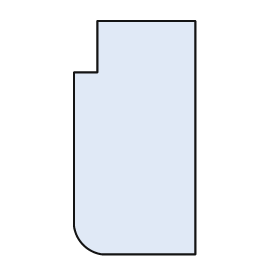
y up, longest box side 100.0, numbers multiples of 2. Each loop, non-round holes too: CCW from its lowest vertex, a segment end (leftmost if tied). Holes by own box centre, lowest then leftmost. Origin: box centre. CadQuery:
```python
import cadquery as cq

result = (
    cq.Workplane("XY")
    .moveTo(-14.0, -50.0)
    .lineTo(26.0, -50.0)
    .lineTo(26.0, 50.0)
    .lineTo(-16.0, 50.0)
    .lineTo(-16.0, 28.0)
    .lineTo(-26.0, 28.0)
    .lineTo(-26.0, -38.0)
    .threePointArc((-22.0, -46.0), (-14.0, -50.0))
    .close()
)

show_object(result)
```